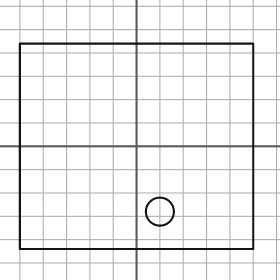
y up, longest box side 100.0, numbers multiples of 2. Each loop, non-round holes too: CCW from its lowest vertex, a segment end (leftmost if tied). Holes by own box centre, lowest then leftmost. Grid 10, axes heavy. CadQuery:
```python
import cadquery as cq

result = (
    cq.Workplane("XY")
    .moveTo(-50.0, -44.0)
    .lineTo(50.0, -44.0)
    .lineTo(50.0, 44.0)
    .lineTo(-50.0, 44.0)
    .close()
    .moveTo(10.0, -28.0)
    .circle(6.0)
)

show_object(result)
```